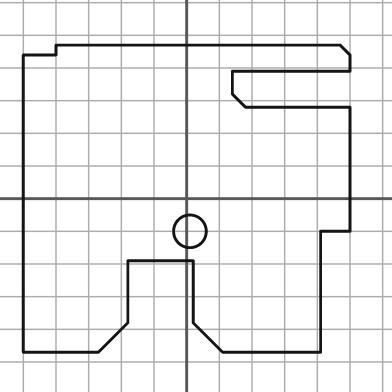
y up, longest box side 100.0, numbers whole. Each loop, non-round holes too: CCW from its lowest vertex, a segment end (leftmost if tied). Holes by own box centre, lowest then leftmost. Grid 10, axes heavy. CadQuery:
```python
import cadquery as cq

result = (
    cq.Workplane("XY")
    .moveTo(-50.0, -47.0)
    .lineTo(-27.0, -47.0)
    .lineTo(-18.0, -38.0)
    .lineTo(-18.0, -19.0)
    .lineTo(2.0, -19.0)
    .lineTo(2.0, -38.0)
    .lineTo(11.0, -47.0)
    .lineTo(41.0, -47.0)
    .lineTo(41.0, -10.0)
    .lineTo(50.0, -10.0)
    .lineTo(50.0, 28.0)
    .lineTo(18.0, 28.0)
    .lineTo(14.0, 32.0)
    .lineTo(14.0, 39.0)
    .lineTo(50.0, 39.0)
    .lineTo(50.0, 44.0)
    .lineTo(47.0, 47.0)
    .lineTo(-40.0, 47.0)
    .lineTo(-40.0, 44.0)
    .lineTo(-50.0, 44.0)
    .close()
    .moveTo(1.0, -10.0)
    .circle(5.0)
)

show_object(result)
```